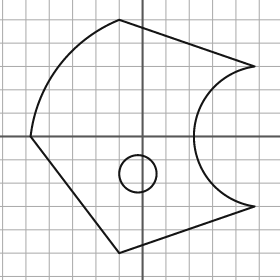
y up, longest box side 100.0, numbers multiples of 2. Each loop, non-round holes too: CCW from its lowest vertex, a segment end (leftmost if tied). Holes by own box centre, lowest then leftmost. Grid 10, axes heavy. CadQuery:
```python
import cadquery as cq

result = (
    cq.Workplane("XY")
    .moveTo(-10.0, -50.0)
    .lineTo(48.0, -30.0)
    .threePointArc((22.0, 0.0), (48.0, 30.0))
    .lineTo(-10.0, 50.0)
    .threePointArc((-36.0, 30.0), (-48.0, 0.0))
    .close()
    .moveTo(-2.0, -16.0)
    .circle(8.0)
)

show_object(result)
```